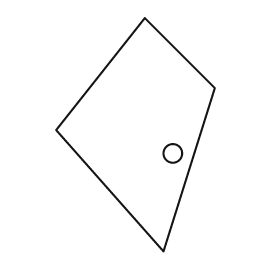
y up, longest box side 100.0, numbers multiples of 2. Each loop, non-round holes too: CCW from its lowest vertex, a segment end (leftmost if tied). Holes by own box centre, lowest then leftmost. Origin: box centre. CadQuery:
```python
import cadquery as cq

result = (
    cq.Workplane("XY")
    .moveTo(12.0, -50.0)
    .lineTo(34.0, 20.0)
    .lineTo(4.0, 50.0)
    .lineTo(-34.0, 2.0)
    .close()
    .moveTo(16.0, -8.0)
    .circle(4.0)
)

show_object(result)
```